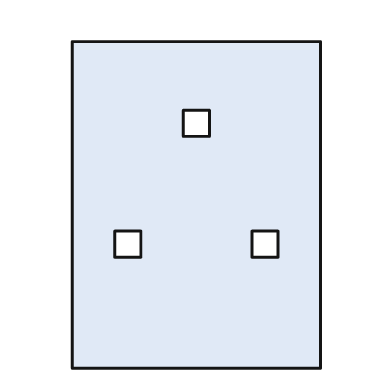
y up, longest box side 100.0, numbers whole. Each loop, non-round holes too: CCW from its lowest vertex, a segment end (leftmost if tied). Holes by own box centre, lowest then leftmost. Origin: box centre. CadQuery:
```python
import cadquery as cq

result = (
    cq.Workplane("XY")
    .moveTo(-38.0, -50.0)
    .lineTo(38.0, -50.0)
    .lineTo(38.0, 50.0)
    .lineTo(-38.0, 50.0)
    .close()
    .moveTo(-25.0, -16.0)
    .lineTo(-17.0, -16.0)
    .lineTo(-17.0, -8.0)
    .lineTo(-25.0, -8.0)
    .close()
    .moveTo(17.0, -16.0)
    .lineTo(25.0, -16.0)
    .lineTo(25.0, -8.0)
    .lineTo(17.0, -8.0)
    .close()
    .moveTo(-4.0, 21.0)
    .lineTo(4.0, 21.0)
    .lineTo(4.0, 29.0)
    .lineTo(-4.0, 29.0)
    .close()
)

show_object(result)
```